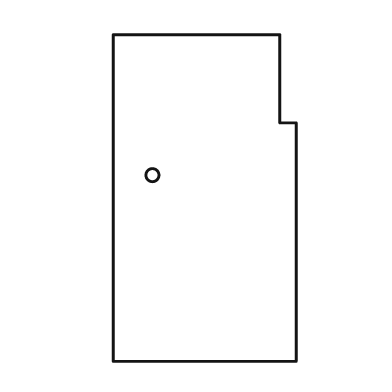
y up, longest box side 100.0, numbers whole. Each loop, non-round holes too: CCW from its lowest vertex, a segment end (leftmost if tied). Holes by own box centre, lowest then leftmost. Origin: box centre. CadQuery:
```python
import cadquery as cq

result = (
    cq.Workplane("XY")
    .moveTo(-28.0, -50.0)
    .lineTo(28.0, -50.0)
    .lineTo(28.0, 23.0)
    .lineTo(23.0, 23.0)
    .lineTo(23.0, 50.0)
    .lineTo(-28.0, 50.0)
    .close()
    .moveTo(-16.0, 7.0)
    .circle(2.0)
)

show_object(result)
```